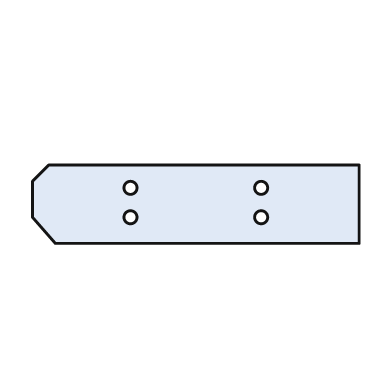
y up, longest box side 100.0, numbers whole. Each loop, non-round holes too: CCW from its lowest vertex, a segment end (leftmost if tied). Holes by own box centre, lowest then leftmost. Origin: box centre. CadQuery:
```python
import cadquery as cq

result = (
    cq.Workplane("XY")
    .moveTo(-43.0, -12.0)
    .lineTo(50.0, -12.0)
    .lineTo(50.0, 12.0)
    .lineTo(-45.0, 12.0)
    .lineTo(-50.0, 7.0)
    .lineTo(-50.0, -4.0)
    .close()
    .moveTo(-20.0, -4.0)
    .circle(2.0)
    .moveTo(20.0, -4.0)
    .circle(2.0)
    .moveTo(-20.0, 5.0)
    .circle(2.0)
    .moveTo(20.0, 5.0)
    .circle(2.0)
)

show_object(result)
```